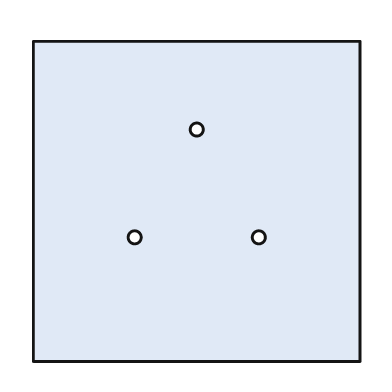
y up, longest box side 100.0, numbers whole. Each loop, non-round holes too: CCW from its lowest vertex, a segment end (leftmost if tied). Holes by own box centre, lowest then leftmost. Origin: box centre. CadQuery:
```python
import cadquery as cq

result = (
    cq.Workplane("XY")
    .moveTo(-50.0, -49.0)
    .lineTo(50.0, -49.0)
    .lineTo(50.0, 49.0)
    .lineTo(-50.0, 49.0)
    .close()
    .moveTo(-19.0, -11.0)
    .circle(2.0)
    .moveTo(19.0, -11.0)
    .circle(2.0)
    .moveTo(0.0, 22.0)
    .circle(2.0)
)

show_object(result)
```